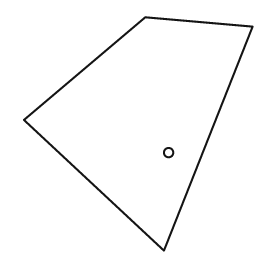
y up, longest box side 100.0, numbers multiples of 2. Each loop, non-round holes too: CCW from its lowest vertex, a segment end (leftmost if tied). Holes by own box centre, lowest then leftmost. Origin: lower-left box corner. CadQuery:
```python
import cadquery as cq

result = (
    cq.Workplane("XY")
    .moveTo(60.0, 0.0)
    .lineTo(98.0, 96.0)
    .lineTo(52.0, 100.0)
    .lineTo(0.0, 56.0)
    .close()
    .moveTo(62.0, 42.0)
    .circle(2.0)
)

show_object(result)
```